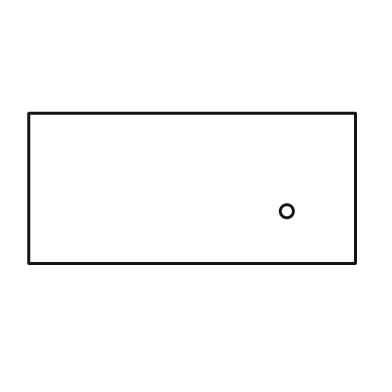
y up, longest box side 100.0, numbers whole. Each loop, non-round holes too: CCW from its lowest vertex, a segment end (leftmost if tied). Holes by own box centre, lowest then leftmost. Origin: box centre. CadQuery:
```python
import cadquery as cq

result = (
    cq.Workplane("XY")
    .moveTo(-50.0, -23.0)
    .lineTo(50.0, -23.0)
    .lineTo(50.0, 23.0)
    .lineTo(-50.0, 23.0)
    .close()
    .moveTo(29.0, -7.0)
    .circle(2.0)
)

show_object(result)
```